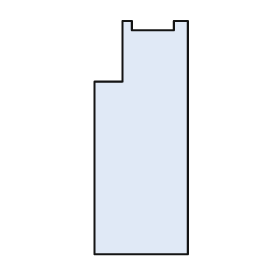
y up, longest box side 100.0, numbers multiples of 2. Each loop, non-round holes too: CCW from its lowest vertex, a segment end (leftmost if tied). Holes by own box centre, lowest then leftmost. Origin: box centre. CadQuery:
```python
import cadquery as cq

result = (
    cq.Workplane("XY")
    .moveTo(-20.0, -50.0)
    .lineTo(20.0, -50.0)
    .lineTo(20.0, 50.0)
    .lineTo(14.0, 50.0)
    .lineTo(14.0, 46.0)
    .lineTo(-4.0, 46.0)
    .lineTo(-4.0, 50.0)
    .lineTo(-8.0, 50.0)
    .lineTo(-8.0, 24.0)
    .lineTo(-20.0, 24.0)
    .close()
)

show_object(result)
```